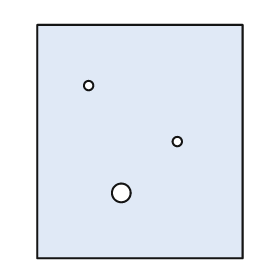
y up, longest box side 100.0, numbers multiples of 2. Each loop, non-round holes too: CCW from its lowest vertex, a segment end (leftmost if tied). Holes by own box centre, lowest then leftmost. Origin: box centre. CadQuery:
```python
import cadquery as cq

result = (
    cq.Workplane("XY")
    .moveTo(-44.0, -50.0)
    .lineTo(44.0, -50.0)
    .lineTo(44.0, 50.0)
    .lineTo(-44.0, 50.0)
    .close()
    .moveTo(-8.0, -22.0)
    .circle(4.0)
    .moveTo(16.0, 0.0)
    .circle(2.0)
    .moveTo(-22.0, 24.0)
    .circle(2.0)
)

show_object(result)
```